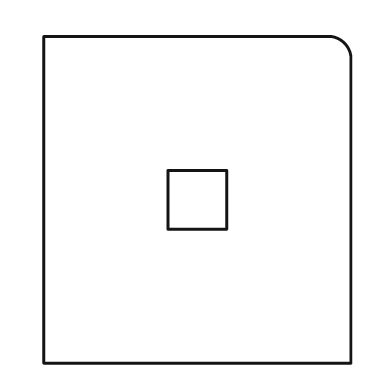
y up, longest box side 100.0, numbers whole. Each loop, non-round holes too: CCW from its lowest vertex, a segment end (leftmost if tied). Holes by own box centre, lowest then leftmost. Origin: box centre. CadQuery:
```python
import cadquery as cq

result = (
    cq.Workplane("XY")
    .moveTo(-47.0, -50.0)
    .lineTo(47.0, -50.0)
    .lineTo(47.0, 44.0)
    .threePointArc((45.0, 48.0), (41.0, 50.0))
    .lineTo(-47.0, 50.0)
    .close()
    .moveTo(-9.0, -9.0)
    .lineTo(9.0, -9.0)
    .lineTo(9.0, 9.0)
    .lineTo(-9.0, 9.0)
    .close()
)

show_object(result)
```